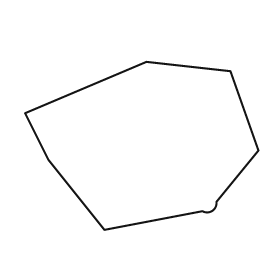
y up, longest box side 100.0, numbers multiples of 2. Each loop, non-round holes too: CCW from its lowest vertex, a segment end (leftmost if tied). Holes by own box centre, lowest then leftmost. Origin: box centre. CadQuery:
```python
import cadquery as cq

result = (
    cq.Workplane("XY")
    .moveTo(-16.0, -36.0)
    .lineTo(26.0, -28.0)
    .threePointArc((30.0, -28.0), (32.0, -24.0))
    .lineTo(50.0, -2.0)
    .lineTo(38.0, 32.0)
    .lineTo(2.0, 36.0)
    .lineTo(-50.0, 14.0)
    .lineTo(-40.0, -6.0)
    .close()
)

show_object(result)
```